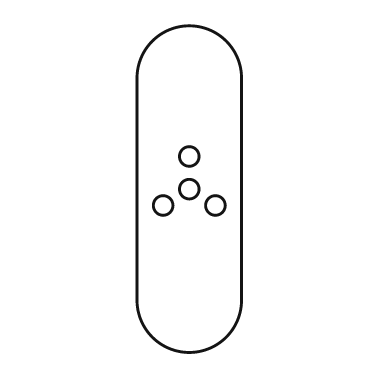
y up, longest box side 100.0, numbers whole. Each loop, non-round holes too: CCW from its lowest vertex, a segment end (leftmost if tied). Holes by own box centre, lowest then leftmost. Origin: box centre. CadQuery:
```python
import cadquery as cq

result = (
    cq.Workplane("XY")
    .moveTo(-16.0, -34.0)
    .threePointArc((0.0, -50.0), (16.0, -34.0))
    .lineTo(16.0, 34.0)
    .threePointArc((0.0, 50.0), (-16.0, 34.0))
    .close()
    .moveTo(-8.0, -5.0)
    .circle(3.0)
    .moveTo(8.0, -5.0)
    .circle(3.0)
    .moveTo(0.0, 0.0)
    .circle(3.0)
    .moveTo(0.0, 10.0)
    .circle(3.0)
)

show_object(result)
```